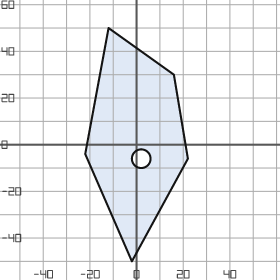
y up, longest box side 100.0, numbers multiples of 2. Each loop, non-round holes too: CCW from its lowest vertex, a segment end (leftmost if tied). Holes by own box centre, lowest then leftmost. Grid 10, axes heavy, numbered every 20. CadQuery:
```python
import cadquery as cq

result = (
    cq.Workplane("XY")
    .moveTo(-2.0, -50.0)
    .lineTo(22.0, -6.0)
    .lineTo(16.0, 30.0)
    .lineTo(-12.0, 50.0)
    .lineTo(-22.0, -4.0)
    .close()
    .moveTo(2.0, -6.0)
    .circle(4.0)
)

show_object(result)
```